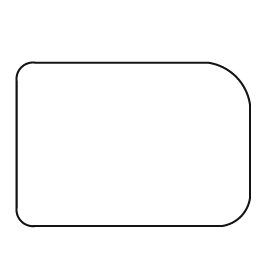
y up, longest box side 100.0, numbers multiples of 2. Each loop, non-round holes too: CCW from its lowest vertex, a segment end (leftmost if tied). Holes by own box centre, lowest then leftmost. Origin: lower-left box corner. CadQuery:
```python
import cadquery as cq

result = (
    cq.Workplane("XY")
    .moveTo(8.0, 0.0)
    .lineTo(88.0, 0.0)
    .threePointArc((96.0, 4.0), (100.0, 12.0))
    .lineTo(100.0, 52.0)
    .threePointArc((94.0, 64.0), (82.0, 70.0))
    .lineTo(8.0, 70.0)
    .threePointArc((2.0, 68.0), (0.0, 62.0))
    .lineTo(0.0, 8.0)
    .threePointArc((2.0, 2.0), (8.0, 0.0))
    .close()
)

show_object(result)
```